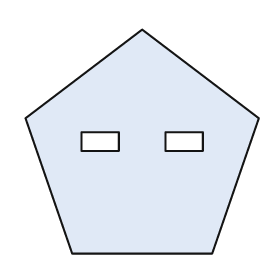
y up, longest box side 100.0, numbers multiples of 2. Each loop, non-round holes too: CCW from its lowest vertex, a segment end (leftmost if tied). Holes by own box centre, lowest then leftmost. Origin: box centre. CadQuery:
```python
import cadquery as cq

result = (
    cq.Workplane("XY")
    .moveTo(-30.0, -48.0)
    .lineTo(30.0, -48.0)
    .lineTo(50.0, 10.0)
    .lineTo(0.0, 48.0)
    .lineTo(-50.0, 10.0)
    .close()
    .moveTo(-26.0, -4.0)
    .lineTo(-10.0, -4.0)
    .lineTo(-10.0, 4.0)
    .lineTo(-26.0, 4.0)
    .close()
    .moveTo(10.0, -4.0)
    .lineTo(26.0, -4.0)
    .lineTo(26.0, 4.0)
    .lineTo(10.0, 4.0)
    .close()
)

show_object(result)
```